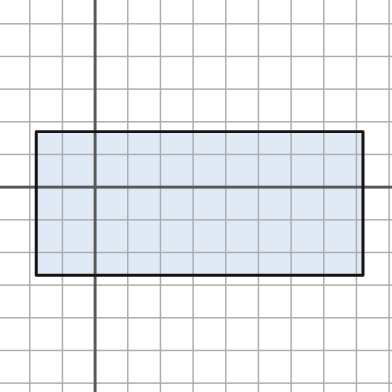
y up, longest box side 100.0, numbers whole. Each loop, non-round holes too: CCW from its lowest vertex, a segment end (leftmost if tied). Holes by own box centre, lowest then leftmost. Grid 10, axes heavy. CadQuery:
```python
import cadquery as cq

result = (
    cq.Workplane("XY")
    .moveTo(-18.0, -27.0)
    .lineTo(82.0, -27.0)
    .lineTo(82.0, 17.0)
    .lineTo(-18.0, 17.0)
    .close()
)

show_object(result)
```